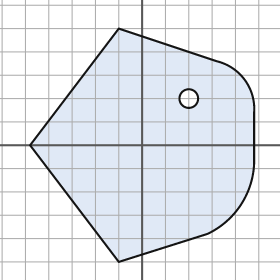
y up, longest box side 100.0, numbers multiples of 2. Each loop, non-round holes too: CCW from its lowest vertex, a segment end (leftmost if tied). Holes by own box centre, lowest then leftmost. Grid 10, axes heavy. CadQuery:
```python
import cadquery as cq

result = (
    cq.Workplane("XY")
    .moveTo(-10.0, -50.0)
    .lineTo(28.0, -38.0)
    .threePointArc((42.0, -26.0), (48.0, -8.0))
    .lineTo(48.0, 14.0)
    .threePointArc((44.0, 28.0), (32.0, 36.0))
    .lineTo(-10.0, 50.0)
    .lineTo(-48.0, 0.0)
    .close()
    .moveTo(20.0, 20.0)
    .circle(4.0)
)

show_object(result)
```